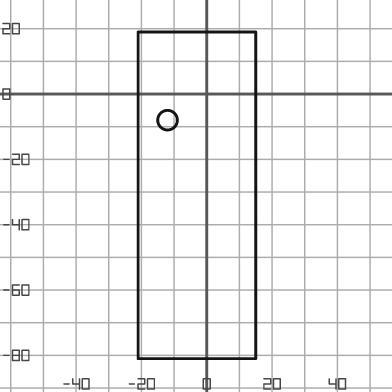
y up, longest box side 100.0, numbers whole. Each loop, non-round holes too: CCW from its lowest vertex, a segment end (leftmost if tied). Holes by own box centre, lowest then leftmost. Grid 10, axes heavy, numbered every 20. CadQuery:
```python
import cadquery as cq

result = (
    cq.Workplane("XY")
    .moveTo(-21.0, -81.0)
    .lineTo(15.0, -81.0)
    .lineTo(15.0, 19.0)
    .lineTo(-21.0, 19.0)
    .close()
    .moveTo(-12.0, -8.0)
    .circle(3.0)
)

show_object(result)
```